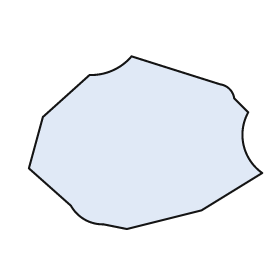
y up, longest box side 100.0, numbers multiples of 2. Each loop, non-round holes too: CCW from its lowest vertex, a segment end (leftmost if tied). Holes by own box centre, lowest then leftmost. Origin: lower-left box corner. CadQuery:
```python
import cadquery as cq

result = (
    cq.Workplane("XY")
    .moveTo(42.0, 0.0)
    .lineTo(74.0, 8.0)
    .lineTo(100.0, 24.0)
    .threePointArc((92.0, 36.0), (94.0, 50.0))
    .lineTo(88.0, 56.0)
    .threePointArc((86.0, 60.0), (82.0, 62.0))
    .lineTo(44.0, 74.0)
    .threePointArc((36.0, 68.0), (26.0, 66.0))
    .lineTo(6.0, 48.0)
    .lineTo(0.0, 26.0)
    .lineTo(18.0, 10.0)
    .threePointArc((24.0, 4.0), (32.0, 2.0))
    .close()
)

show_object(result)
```